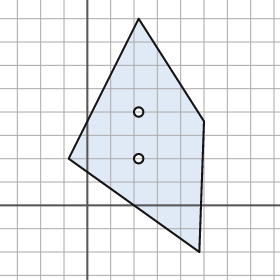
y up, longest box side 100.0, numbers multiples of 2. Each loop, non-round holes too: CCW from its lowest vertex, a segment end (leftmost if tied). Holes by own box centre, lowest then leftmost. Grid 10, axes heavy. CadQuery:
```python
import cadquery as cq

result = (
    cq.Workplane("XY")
    .moveTo(48.0, -20.0)
    .lineTo(50.0, 36.0)
    .lineTo(22.0, 80.0)
    .lineTo(-8.0, 20.0)
    .close()
    .moveTo(22.0, 20.0)
    .circle(2.0)
    .moveTo(22.0, 40.0)
    .circle(2.0)
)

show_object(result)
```